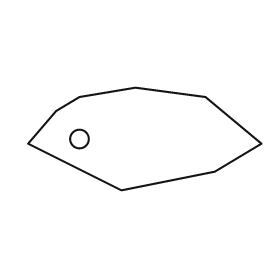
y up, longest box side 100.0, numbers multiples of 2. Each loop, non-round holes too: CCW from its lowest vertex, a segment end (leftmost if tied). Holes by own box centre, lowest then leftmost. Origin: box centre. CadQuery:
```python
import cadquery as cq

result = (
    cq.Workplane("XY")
    .moveTo(-10.0, -22.0)
    .lineTo(30.0, -14.0)
    .lineTo(50.0, -2.0)
    .lineTo(26.0, 18.0)
    .lineTo(-4.0, 22.0)
    .lineTo(-28.0, 18.0)
    .lineTo(-38.0, 12.0)
    .lineTo(-50.0, -2.0)
    .close()
    .moveTo(-28.0, 0.0)
    .circle(4.0)
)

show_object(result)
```